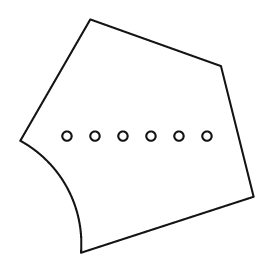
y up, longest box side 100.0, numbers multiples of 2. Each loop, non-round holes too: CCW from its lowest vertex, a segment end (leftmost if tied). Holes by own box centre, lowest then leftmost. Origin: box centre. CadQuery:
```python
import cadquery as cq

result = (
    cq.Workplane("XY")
    .moveTo(-24.0, -50.0)
    .lineTo(50.0, -26.0)
    .lineTo(36.0, 30.0)
    .lineTo(-20.0, 50.0)
    .lineTo(-50.0, -2.0)
    .threePointArc((-30.0, -22.0), (-24.0, -50.0))
    .close()
    .moveTo(-30.0, 0.0)
    .circle(2.0)
    .moveTo(-18.0, 0.0)
    .circle(2.0)
    .moveTo(-6.0, 0.0)
    .circle(2.0)
    .moveTo(6.0, 0.0)
    .circle(2.0)
    .moveTo(18.0, 0.0)
    .circle(2.0)
    .moveTo(30.0, 0.0)
    .circle(2.0)
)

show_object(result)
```